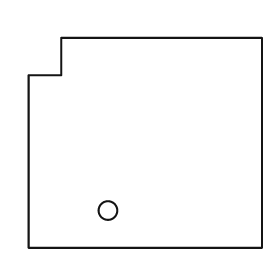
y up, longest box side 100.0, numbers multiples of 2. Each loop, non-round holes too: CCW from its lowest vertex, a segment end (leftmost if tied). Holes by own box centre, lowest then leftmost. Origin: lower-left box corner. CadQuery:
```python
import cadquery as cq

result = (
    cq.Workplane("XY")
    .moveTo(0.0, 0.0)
    .lineTo(100.0, 0.0)
    .lineTo(100.0, 90.0)
    .lineTo(14.0, 90.0)
    .lineTo(14.0, 74.0)
    .lineTo(0.0, 74.0)
    .close()
    .moveTo(34.0, 16.0)
    .circle(4.0)
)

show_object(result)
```